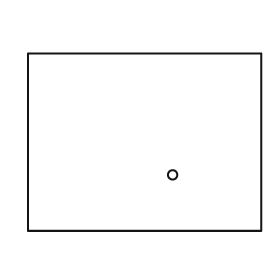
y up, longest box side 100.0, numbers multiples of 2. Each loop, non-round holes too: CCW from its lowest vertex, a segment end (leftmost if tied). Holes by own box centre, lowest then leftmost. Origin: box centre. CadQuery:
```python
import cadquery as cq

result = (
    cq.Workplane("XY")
    .moveTo(-50.0, -38.0)
    .lineTo(50.0, -38.0)
    .lineTo(50.0, 38.0)
    .lineTo(-50.0, 38.0)
    .close()
    .moveTo(12.0, -14.0)
    .circle(2.0)
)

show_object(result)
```